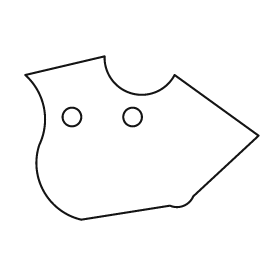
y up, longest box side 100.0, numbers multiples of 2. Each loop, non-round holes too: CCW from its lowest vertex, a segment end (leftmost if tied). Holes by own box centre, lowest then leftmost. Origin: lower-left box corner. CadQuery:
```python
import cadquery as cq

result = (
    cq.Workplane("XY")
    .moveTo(24.0, 0.0)
    .lineTo(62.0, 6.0)
    .threePointArc((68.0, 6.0), (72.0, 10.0))
    .lineTo(100.0, 36.0)
    .lineTo(64.0, 62.0)
    .threePointArc((46.0, 54.0), (34.0, 70.0))
    .lineTo(0.0, 62.0)
    .threePointArc((8.0, 48.0), (6.0, 32.0))
    .threePointArc((8.0, 12.0), (24.0, 0.0))
    .close()
    .moveTo(20.0, 44.0)
    .circle(4.0)
    .moveTo(46.0, 44.0)
    .circle(4.0)
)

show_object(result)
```